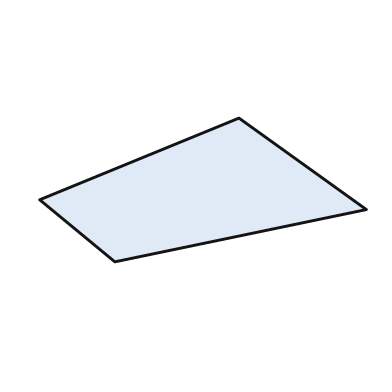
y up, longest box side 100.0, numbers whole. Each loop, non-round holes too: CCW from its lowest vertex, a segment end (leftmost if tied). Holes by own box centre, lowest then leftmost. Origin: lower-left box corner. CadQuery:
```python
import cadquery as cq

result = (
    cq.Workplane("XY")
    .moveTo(23.0, 0.0)
    .lineTo(100.0, 16.0)
    .lineTo(61.0, 44.0)
    .lineTo(0.0, 19.0)
    .close()
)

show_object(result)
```